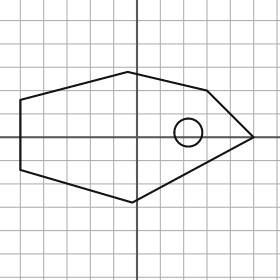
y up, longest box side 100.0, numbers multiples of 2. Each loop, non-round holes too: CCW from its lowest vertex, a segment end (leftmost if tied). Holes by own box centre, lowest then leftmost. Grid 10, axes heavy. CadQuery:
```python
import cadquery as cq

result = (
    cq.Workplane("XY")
    .moveTo(-2.0, -28.0)
    .lineTo(50.0, 0.0)
    .lineTo(30.0, 20.0)
    .lineTo(-4.0, 28.0)
    .lineTo(-50.0, 16.0)
    .lineTo(-50.0, -14.0)
    .close()
    .moveTo(22.0, 2.0)
    .circle(6.0)
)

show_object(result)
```